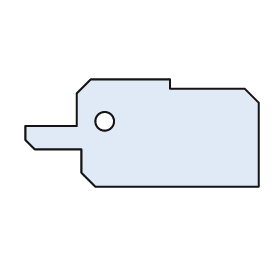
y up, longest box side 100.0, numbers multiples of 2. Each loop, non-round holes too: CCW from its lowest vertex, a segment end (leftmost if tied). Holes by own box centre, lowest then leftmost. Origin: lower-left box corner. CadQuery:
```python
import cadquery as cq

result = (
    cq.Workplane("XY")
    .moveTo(30.0, 0.0)
    .lineTo(100.0, 0.0)
    .lineTo(100.0, 36.0)
    .lineTo(94.0, 42.0)
    .lineTo(62.0, 42.0)
    .lineTo(62.0, 46.0)
    .lineTo(28.0, 46.0)
    .lineTo(22.0, 40.0)
    .lineTo(22.0, 26.0)
    .lineTo(0.0, 26.0)
    .lineTo(0.0, 20.0)
    .lineTo(4.0, 16.0)
    .lineTo(24.0, 16.0)
    .lineTo(24.0, 6.0)
    .close()
    .moveTo(34.0, 28.0)
    .circle(4.0)
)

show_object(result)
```